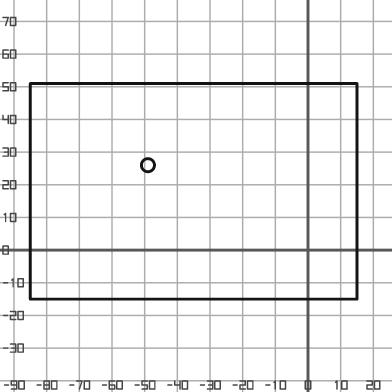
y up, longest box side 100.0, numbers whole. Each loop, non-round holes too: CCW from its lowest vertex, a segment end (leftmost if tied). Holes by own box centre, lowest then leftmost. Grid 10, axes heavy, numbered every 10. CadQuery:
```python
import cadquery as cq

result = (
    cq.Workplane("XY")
    .moveTo(-85.0, -15.0)
    .lineTo(15.0, -15.0)
    .lineTo(15.0, 51.0)
    .lineTo(-85.0, 51.0)
    .close()
    .moveTo(-49.0, 26.0)
    .circle(2.0)
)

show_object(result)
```